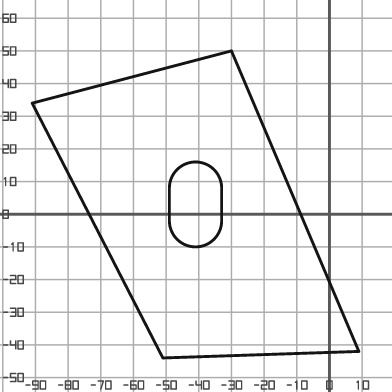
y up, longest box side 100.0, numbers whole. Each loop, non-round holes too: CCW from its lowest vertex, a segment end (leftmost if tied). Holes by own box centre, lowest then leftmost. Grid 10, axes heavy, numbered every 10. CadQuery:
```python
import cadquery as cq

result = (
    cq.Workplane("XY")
    .moveTo(-51.0, -44.0)
    .lineTo(9.0, -42.0)
    .lineTo(-30.0, 50.0)
    .lineTo(-91.0, 34.0)
    .close()
    .moveTo(-49.0, -2.0)
    .threePointArc((-41.0, -10.0), (-33.0, -2.0))
    .lineTo(-33.0, 8.0)
    .threePointArc((-41.0, 16.0), (-49.0, 8.0))
    .close()
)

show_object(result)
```